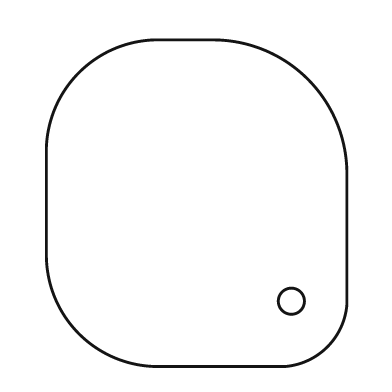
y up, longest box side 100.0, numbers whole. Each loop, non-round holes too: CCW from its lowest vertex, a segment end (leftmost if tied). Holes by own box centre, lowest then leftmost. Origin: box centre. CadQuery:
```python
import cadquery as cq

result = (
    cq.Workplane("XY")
    .moveTo(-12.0, -50.0)
    .lineTo(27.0, -50.0)
    .threePointArc((40.0, -44.0), (46.0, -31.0))
    .lineTo(46.0, 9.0)
    .threePointArc((34.0, 38.0), (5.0, 50.0))
    .lineTo(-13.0, 50.0)
    .threePointArc((-36.0, 40.0), (-46.0, 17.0))
    .lineTo(-46.0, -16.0)
    .threePointArc((-36.0, -40.0), (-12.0, -50.0))
    .close()
    .moveTo(29.0, -30.0)
    .circle(4.0)
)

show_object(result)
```